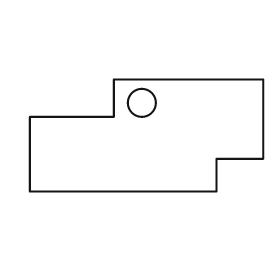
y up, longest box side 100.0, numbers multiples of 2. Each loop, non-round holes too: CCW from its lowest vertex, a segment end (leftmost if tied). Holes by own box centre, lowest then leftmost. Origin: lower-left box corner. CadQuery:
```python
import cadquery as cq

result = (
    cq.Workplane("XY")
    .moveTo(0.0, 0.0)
    .lineTo(80.0, 0.0)
    .lineTo(80.0, 14.0)
    .lineTo(100.0, 14.0)
    .lineTo(100.0, 48.0)
    .lineTo(36.0, 48.0)
    .lineTo(36.0, 32.0)
    .lineTo(0.0, 32.0)
    .close()
    .moveTo(48.0, 38.0)
    .circle(6.0)
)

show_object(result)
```